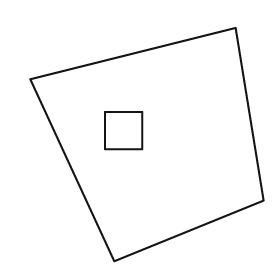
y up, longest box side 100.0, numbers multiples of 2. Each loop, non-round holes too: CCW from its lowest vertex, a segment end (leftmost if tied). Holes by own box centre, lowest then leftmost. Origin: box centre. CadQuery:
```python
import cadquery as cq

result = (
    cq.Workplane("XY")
    .moveTo(-14.0, -50.0)
    .lineTo(50.0, -24.0)
    .lineTo(38.0, 50.0)
    .lineTo(-50.0, 28.0)
    .close()
    .moveTo(-18.0, -2.0)
    .lineTo(-2.0, -2.0)
    .lineTo(-2.0, 14.0)
    .lineTo(-18.0, 14.0)
    .close()
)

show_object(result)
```